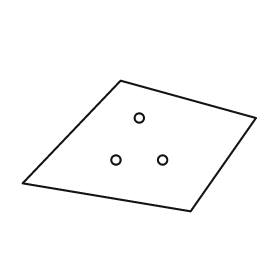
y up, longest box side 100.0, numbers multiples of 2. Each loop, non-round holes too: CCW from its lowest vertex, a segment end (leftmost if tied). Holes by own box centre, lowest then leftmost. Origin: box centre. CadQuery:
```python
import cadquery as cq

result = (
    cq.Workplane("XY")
    .moveTo(22.0, -28.0)
    .lineTo(50.0, 12.0)
    .lineTo(-8.0, 28.0)
    .lineTo(-50.0, -16.0)
    .close()
    .moveTo(-10.0, -6.0)
    .circle(2.0)
    .moveTo(10.0, -6.0)
    .circle(2.0)
    .moveTo(0.0, 12.0)
    .circle(2.0)
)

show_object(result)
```